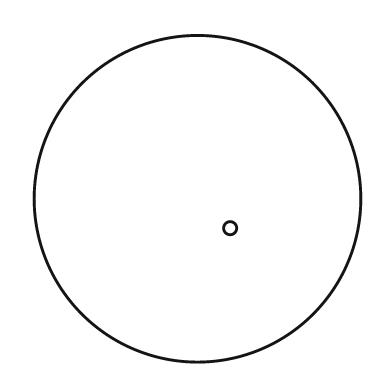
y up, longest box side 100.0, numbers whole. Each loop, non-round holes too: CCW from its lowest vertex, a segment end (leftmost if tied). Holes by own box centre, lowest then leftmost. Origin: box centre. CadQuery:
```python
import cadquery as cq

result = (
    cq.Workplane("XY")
    .moveTo(0.0, 0.0)
    .circle(50.0)
    .moveTo(10.0, -9.0)
    .circle(2.0)
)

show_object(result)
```